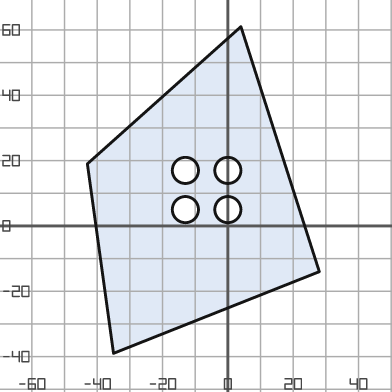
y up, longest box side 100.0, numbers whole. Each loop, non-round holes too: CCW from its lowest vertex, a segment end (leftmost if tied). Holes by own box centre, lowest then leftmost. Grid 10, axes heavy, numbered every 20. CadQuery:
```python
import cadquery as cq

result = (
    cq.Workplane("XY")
    .moveTo(-35.0, -39.0)
    .lineTo(28.0, -14.0)
    .lineTo(4.0, 61.0)
    .lineTo(-43.0, 19.0)
    .close()
    .moveTo(-13.0, 5.0)
    .circle(4.0)
    .moveTo(0.0, 5.0)
    .circle(4.0)
    .moveTo(-13.0, 17.0)
    .circle(4.0)
    .moveTo(0.0, 17.0)
    .circle(4.0)
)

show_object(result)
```